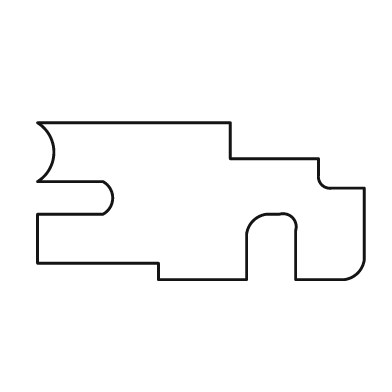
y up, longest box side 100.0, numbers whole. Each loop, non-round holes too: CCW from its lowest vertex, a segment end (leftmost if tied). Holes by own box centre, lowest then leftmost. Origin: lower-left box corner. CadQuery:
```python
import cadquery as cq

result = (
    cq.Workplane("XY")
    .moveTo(37.0, 0.0)
    .lineTo(64.0, 0.0)
    .lineTo(64.0, 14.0)
    .threePointArc((66.0, 18.0), (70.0, 20.0))
    .lineTo(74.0, 20.0)
    .threePointArc((78.0, 19.0), (79.0, 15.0))
    .lineTo(79.0, 0.0)
    .lineTo(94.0, 0.0)
    .threePointArc((98.0, 2.0), (100.0, 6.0))
    .lineTo(100.0, 28.0)
    .lineTo(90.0, 28.0)
    .threePointArc((87.0, 29.0), (86.0, 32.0))
    .lineTo(86.0, 37.0)
    .lineTo(59.0, 37.0)
    .lineTo(59.0, 48.0)
    .lineTo(0.0, 48.0)
    .threePointArc((5.0, 39.0), (0.0, 30.0))
    .lineTo(20.0, 30.0)
    .threePointArc((23.0, 25.0), (20.0, 20.0))
    .lineTo(0.0, 20.0)
    .lineTo(0.0, 5.0)
    .lineTo(37.0, 5.0)
    .close()
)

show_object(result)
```